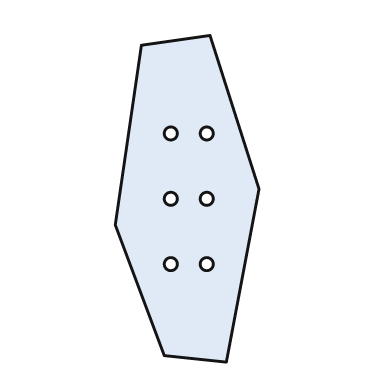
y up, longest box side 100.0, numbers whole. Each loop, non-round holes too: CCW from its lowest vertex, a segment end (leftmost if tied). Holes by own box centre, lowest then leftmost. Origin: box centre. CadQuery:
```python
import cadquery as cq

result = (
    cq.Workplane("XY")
    .moveTo(12.0, -50.0)
    .lineTo(22.0, 3.0)
    .lineTo(7.0, 50.0)
    .lineTo(-14.0, 47.0)
    .lineTo(-22.0, -8.0)
    .lineTo(-7.0, -48.0)
    .close()
    .moveTo(-5.0, -20.0)
    .circle(2.0)
    .moveTo(6.0, -20.0)
    .circle(2.0)
    .moveTo(-5.0, 0.0)
    .circle(2.0)
    .moveTo(6.0, 0.0)
    .circle(2.0)
    .moveTo(-5.0, 20.0)
    .circle(2.0)
    .moveTo(6.0, 20.0)
    .circle(2.0)
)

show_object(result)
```